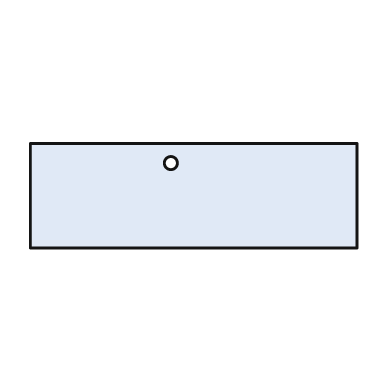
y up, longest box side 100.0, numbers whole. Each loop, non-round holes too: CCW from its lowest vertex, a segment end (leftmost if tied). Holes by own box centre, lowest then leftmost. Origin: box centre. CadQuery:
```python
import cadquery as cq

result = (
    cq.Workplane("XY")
    .moveTo(-50.0, -16.0)
    .lineTo(50.0, -16.0)
    .lineTo(50.0, 16.0)
    .lineTo(-50.0, 16.0)
    .close()
    .moveTo(-7.0, 10.0)
    .circle(2.0)
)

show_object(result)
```